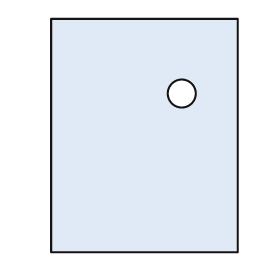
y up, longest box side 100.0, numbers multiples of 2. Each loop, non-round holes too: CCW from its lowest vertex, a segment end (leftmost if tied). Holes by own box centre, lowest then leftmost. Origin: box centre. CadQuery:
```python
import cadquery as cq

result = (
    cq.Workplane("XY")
    .moveTo(-40.0, -50.0)
    .lineTo(40.0, -50.0)
    .lineTo(40.0, 50.0)
    .lineTo(-40.0, 50.0)
    .close()
    .moveTo(16.0, 18.0)
    .circle(6.0)
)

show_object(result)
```